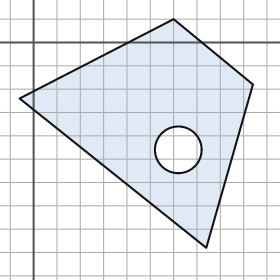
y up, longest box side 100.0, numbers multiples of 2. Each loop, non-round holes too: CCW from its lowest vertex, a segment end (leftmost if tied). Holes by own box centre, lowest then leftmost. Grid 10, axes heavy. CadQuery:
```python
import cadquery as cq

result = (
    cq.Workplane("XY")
    .moveTo(74.0, -88.0)
    .lineTo(94.0, -18.0)
    .lineTo(60.0, 10.0)
    .lineTo(-6.0, -24.0)
    .close()
    .moveTo(62.0, -46.0)
    .circle(10.0)
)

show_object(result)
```